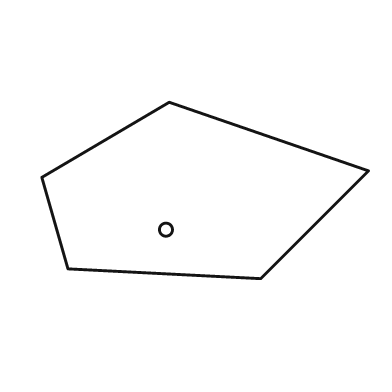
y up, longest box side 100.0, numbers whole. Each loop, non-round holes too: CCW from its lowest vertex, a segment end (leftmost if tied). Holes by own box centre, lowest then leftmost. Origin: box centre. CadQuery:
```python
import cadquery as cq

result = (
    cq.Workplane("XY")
    .moveTo(17.0, -27.0)
    .lineTo(50.0, 6.0)
    .lineTo(-11.0, 27.0)
    .lineTo(-50.0, 4.0)
    .lineTo(-42.0, -24.0)
    .close()
    .moveTo(-12.0, -12.0)
    .circle(2.0)
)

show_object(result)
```